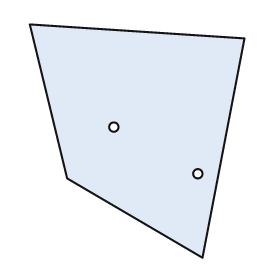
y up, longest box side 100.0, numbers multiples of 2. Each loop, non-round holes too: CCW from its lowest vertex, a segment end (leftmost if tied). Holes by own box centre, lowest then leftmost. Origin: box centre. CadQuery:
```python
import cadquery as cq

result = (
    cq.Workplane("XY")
    .moveTo(28.0, -50.0)
    .lineTo(46.0, 44.0)
    .lineTo(-46.0, 50.0)
    .lineTo(-30.0, -16.0)
    .close()
    .moveTo(26.0, -14.0)
    .circle(2.0)
    .moveTo(-10.0, 6.0)
    .circle(2.0)
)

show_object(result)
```